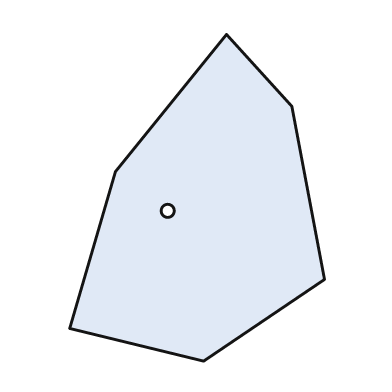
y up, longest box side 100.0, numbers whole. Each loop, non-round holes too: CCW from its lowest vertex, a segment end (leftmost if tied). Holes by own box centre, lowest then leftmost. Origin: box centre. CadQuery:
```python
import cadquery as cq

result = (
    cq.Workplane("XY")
    .moveTo(2.0, -50.0)
    .lineTo(39.0, -25.0)
    .lineTo(29.0, 28.0)
    .lineTo(9.0, 50.0)
    .lineTo(-25.0, 8.0)
    .lineTo(-39.0, -40.0)
    .close()
    .moveTo(-9.0, -4.0)
    .circle(2.0)
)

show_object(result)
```